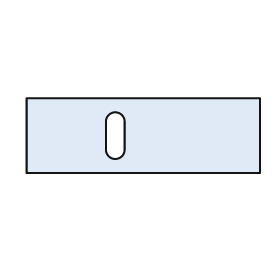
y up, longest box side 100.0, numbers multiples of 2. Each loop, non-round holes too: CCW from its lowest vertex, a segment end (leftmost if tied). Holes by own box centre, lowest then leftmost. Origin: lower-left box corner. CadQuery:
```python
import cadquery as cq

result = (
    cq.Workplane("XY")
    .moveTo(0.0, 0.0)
    .lineTo(100.0, 0.0)
    .lineTo(100.0, 32.0)
    .lineTo(0.0, 32.0)
    .close()
    .moveTo(34.0, 10.0)
    .threePointArc((38.0, 6.0), (42.0, 10.0))
    .lineTo(42.0, 22.0)
    .threePointArc((38.0, 26.0), (34.0, 22.0))
    .close()
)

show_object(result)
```